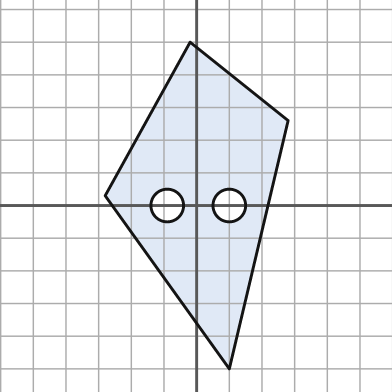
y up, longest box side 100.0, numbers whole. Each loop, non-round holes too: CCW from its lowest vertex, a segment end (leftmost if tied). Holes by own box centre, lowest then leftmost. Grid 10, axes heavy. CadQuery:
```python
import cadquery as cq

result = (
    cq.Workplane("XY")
    .moveTo(10.0, -50.0)
    .lineTo(28.0, 26.0)
    .lineTo(-2.0, 50.0)
    .lineTo(-28.0, 3.0)
    .close()
    .moveTo(-9.0, 0.0)
    .circle(5.0)
    .moveTo(10.0, 0.0)
    .circle(5.0)
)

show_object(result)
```